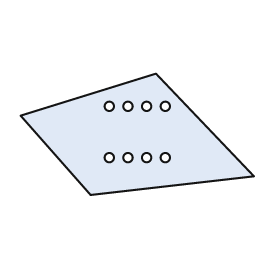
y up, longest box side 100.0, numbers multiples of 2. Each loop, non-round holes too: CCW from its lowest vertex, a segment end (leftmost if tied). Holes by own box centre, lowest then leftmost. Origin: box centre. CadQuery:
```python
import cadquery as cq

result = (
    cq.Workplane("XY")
    .moveTo(-20.0, -26.0)
    .lineTo(50.0, -18.0)
    .lineTo(8.0, 26.0)
    .lineTo(-50.0, 8.0)
    .close()
    .moveTo(-12.0, -10.0)
    .circle(2.0)
    .moveTo(-4.0, -10.0)
    .circle(2.0)
    .moveTo(4.0, -10.0)
    .circle(2.0)
    .moveTo(12.0, -10.0)
    .circle(2.0)
    .moveTo(-12.0, 12.0)
    .circle(2.0)
    .moveTo(-4.0, 12.0)
    .circle(2.0)
    .moveTo(4.0, 12.0)
    .circle(2.0)
    .moveTo(12.0, 12.0)
    .circle(2.0)
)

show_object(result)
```